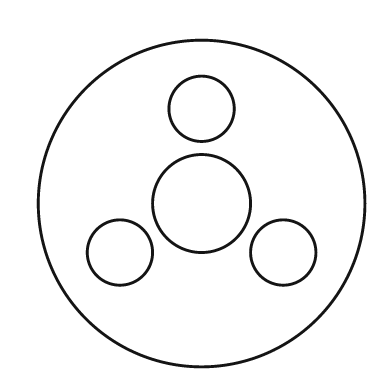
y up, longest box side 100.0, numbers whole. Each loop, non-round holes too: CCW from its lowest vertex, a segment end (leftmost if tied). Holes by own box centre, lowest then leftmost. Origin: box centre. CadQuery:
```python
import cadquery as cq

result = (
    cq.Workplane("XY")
    .moveTo(0.0, 0.0)
    .circle(50.0)
    .moveTo(-25.0, -15.0)
    .circle(10.0)
    .moveTo(25.0, -15.0)
    .circle(10.0)
    .moveTo(0.0, 0.0)
    .circle(15.0)
    .moveTo(0.0, 29.0)
    .circle(10.0)
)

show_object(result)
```